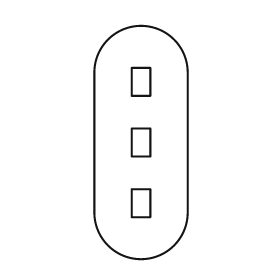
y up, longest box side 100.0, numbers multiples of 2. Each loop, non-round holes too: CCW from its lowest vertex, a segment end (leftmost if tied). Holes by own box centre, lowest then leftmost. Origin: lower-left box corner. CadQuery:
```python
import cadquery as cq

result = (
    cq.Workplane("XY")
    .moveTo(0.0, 20.0)
    .threePointArc((20.0, 0.0), (40.0, 20.0))
    .lineTo(40.0, 80.0)
    .threePointArc((20.0, 100.0), (0.0, 80.0))
    .close()
    .moveTo(16.0, 18.0)
    .lineTo(24.0, 18.0)
    .lineTo(24.0, 30.0)
    .lineTo(16.0, 30.0)
    .close()
    .moveTo(16.0, 44.0)
    .lineTo(24.0, 44.0)
    .lineTo(24.0, 56.0)
    .lineTo(16.0, 56.0)
    .close()
    .moveTo(16.0, 70.0)
    .lineTo(24.0, 70.0)
    .lineTo(24.0, 82.0)
    .lineTo(16.0, 82.0)
    .close()
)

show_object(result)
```